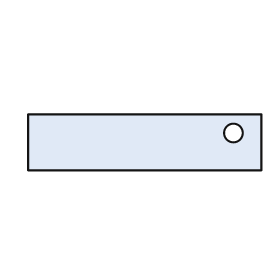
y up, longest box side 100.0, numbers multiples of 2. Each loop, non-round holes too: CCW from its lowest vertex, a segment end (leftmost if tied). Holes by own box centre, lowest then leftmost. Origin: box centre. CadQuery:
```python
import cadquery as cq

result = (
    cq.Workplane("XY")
    .moveTo(-50.0, -12.0)
    .lineTo(50.0, -12.0)
    .lineTo(50.0, 12.0)
    .lineTo(-50.0, 12.0)
    .close()
    .moveTo(38.0, 4.0)
    .circle(4.0)
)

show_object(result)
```